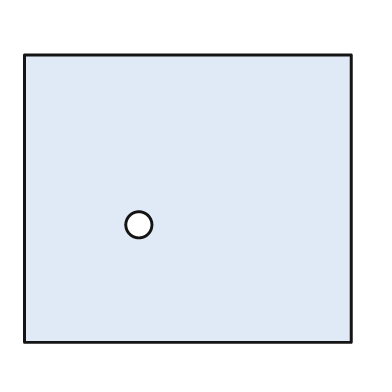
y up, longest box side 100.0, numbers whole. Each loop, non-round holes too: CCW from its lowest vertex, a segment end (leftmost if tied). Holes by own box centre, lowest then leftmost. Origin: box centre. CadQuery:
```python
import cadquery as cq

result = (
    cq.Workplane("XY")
    .moveTo(-50.0, -44.0)
    .lineTo(50.0, -44.0)
    .lineTo(50.0, 44.0)
    .lineTo(-50.0, 44.0)
    .close()
    .moveTo(-15.0, -8.0)
    .circle(4.0)
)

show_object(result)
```